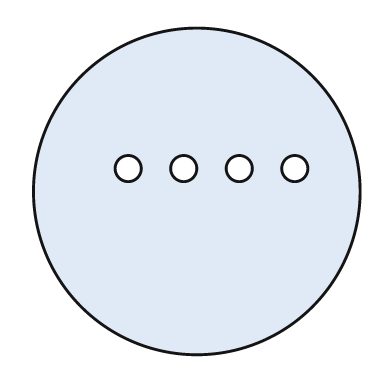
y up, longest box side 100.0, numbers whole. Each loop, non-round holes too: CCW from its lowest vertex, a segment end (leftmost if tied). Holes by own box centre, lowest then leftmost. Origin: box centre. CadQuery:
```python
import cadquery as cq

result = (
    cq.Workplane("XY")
    .moveTo(0.0, 0.0)
    .circle(50.0)
    .moveTo(-21.0, 7.0)
    .circle(4.0)
    .moveTo(-4.0, 7.0)
    .circle(4.0)
    .moveTo(13.0, 7.0)
    .circle(4.0)
    .moveTo(30.0, 7.0)
    .circle(4.0)
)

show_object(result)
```